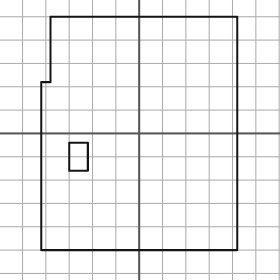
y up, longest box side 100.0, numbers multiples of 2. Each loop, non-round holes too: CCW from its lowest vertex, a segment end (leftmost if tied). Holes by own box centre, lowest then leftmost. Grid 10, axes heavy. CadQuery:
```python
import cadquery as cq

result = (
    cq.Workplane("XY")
    .moveTo(-42.0, -50.0)
    .lineTo(42.0, -50.0)
    .lineTo(42.0, 50.0)
    .lineTo(-38.0, 50.0)
    .lineTo(-38.0, 22.0)
    .lineTo(-42.0, 22.0)
    .close()
    .moveTo(-30.0, -16.0)
    .lineTo(-22.0, -16.0)
    .lineTo(-22.0, -4.0)
    .lineTo(-30.0, -4.0)
    .close()
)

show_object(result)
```